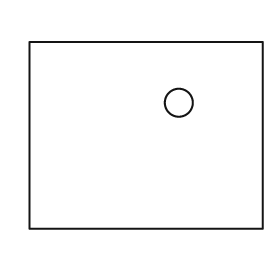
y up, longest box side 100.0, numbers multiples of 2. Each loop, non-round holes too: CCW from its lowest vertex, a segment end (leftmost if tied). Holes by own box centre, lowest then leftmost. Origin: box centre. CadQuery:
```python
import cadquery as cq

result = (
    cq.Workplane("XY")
    .moveTo(-50.0, -40.0)
    .lineTo(50.0, -40.0)
    .lineTo(50.0, 40.0)
    .lineTo(-50.0, 40.0)
    .close()
    .moveTo(14.0, 14.0)
    .circle(6.0)
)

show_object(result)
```